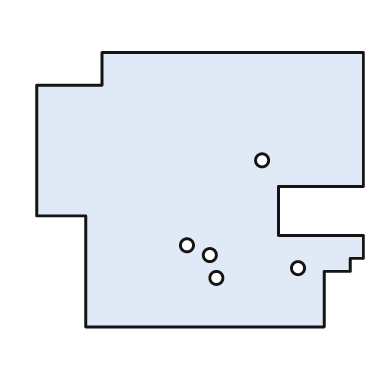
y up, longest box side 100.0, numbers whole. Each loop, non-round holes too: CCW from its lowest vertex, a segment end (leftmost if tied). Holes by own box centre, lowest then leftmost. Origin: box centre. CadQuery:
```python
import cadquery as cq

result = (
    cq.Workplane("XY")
    .moveTo(-35.0, -42.0)
    .lineTo(38.0, -42.0)
    .lineTo(38.0, -25.0)
    .lineTo(46.0, -25.0)
    .lineTo(46.0, -21.0)
    .lineTo(50.0, -21.0)
    .lineTo(50.0, -14.0)
    .lineTo(24.0, -14.0)
    .lineTo(24.0, 1.0)
    .lineTo(50.0, 1.0)
    .lineTo(50.0, 42.0)
    .lineTo(-30.0, 42.0)
    .lineTo(-30.0, 32.0)
    .lineTo(-50.0, 32.0)
    .lineTo(-50.0, -8.0)
    .lineTo(-35.0, -8.0)
    .close()
    .moveTo(5.0, -27.0)
    .circle(2.0)
    .moveTo(30.0, -24.0)
    .circle(2.0)
    .moveTo(3.0, -20.0)
    .circle(2.0)
    .moveTo(-4.0, -17.0)
    .circle(2.0)
    .moveTo(19.0, 9.0)
    .circle(2.0)
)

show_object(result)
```